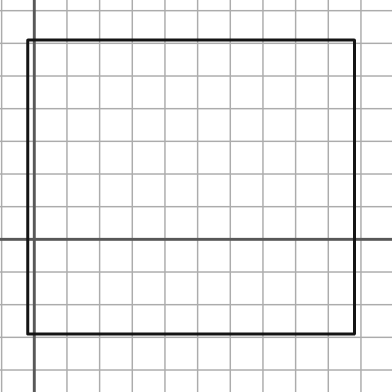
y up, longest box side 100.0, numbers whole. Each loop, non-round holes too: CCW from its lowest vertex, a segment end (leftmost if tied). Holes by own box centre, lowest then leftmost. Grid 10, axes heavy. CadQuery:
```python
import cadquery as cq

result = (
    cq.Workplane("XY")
    .moveTo(-2.0, -29.0)
    .lineTo(98.0, -29.0)
    .lineTo(98.0, 61.0)
    .lineTo(-2.0, 61.0)
    .close()
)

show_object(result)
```